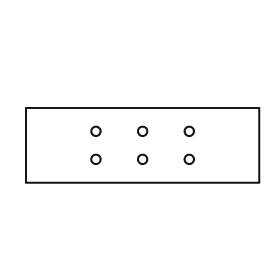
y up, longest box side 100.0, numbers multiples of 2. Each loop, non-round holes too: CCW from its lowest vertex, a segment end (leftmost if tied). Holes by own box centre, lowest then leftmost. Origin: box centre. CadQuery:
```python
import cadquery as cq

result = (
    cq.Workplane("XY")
    .moveTo(-50.0, -16.0)
    .lineTo(50.0, -16.0)
    .lineTo(50.0, 16.0)
    .lineTo(-50.0, 16.0)
    .close()
    .moveTo(-20.0, -6.0)
    .circle(2.0)
    .moveTo(0.0, -6.0)
    .circle(2.0)
    .moveTo(20.0, -6.0)
    .circle(2.0)
    .moveTo(-20.0, 6.0)
    .circle(2.0)
    .moveTo(0.0, 6.0)
    .circle(2.0)
    .moveTo(20.0, 6.0)
    .circle(2.0)
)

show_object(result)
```